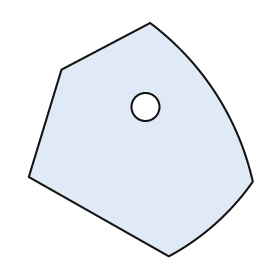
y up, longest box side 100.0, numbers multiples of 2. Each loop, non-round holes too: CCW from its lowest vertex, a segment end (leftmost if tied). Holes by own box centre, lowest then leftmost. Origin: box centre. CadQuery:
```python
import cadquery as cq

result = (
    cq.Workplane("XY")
    .moveTo(12.0, -50.0)
    .threePointArc((32.0, -36.0), (48.0, -18.0))
    .threePointArc((32.0, 20.0), (4.0, 50.0))
    .lineTo(-34.0, 30.0)
    .lineTo(-48.0, -16.0)
    .close()
    .moveTo(2.0, 14.0)
    .circle(6.0)
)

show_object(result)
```